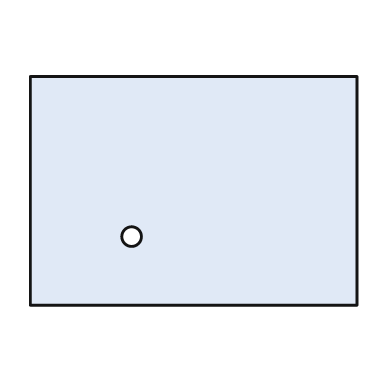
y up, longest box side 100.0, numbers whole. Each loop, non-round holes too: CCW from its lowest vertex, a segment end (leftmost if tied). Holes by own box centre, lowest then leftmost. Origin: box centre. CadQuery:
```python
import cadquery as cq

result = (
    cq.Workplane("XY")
    .moveTo(-50.0, -35.0)
    .lineTo(50.0, -35.0)
    .lineTo(50.0, 35.0)
    .lineTo(-50.0, 35.0)
    .close()
    .moveTo(-19.0, -14.0)
    .circle(3.0)
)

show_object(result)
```